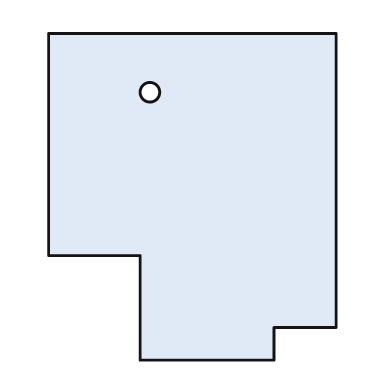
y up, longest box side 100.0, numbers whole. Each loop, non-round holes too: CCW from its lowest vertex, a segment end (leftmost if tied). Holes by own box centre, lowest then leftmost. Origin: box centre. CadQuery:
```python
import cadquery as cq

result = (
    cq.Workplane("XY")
    .moveTo(-16.0, -50.0)
    .lineTo(25.0, -50.0)
    .lineTo(25.0, -40.0)
    .lineTo(44.0, -40.0)
    .lineTo(44.0, 50.0)
    .lineTo(-44.0, 50.0)
    .lineTo(-44.0, -18.0)
    .lineTo(-16.0, -18.0)
    .close()
    .moveTo(-13.0, 32.0)
    .circle(3.0)
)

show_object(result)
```